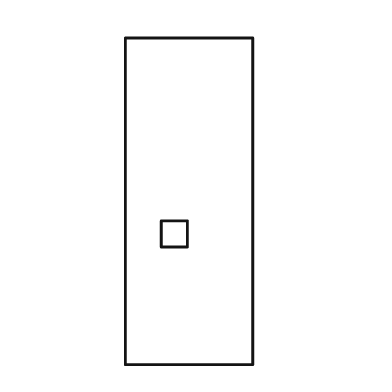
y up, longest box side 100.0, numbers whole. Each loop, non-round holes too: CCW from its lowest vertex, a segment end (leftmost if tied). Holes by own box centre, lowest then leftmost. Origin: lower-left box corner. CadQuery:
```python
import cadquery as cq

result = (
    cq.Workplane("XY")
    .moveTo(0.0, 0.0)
    .lineTo(39.0, 0.0)
    .lineTo(39.0, 100.0)
    .lineTo(0.0, 100.0)
    .close()
    .moveTo(11.0, 36.0)
    .lineTo(19.0, 36.0)
    .lineTo(19.0, 44.0)
    .lineTo(11.0, 44.0)
    .close()
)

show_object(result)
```